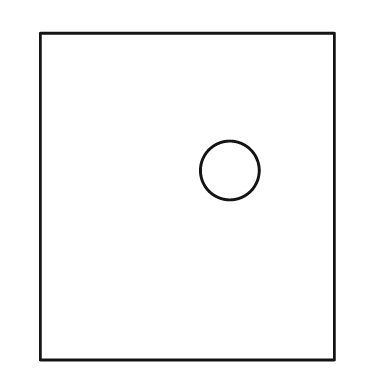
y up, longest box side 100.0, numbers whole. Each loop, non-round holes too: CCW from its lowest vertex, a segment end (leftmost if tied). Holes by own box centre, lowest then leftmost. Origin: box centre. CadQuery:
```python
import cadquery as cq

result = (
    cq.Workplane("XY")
    .moveTo(-45.0, -50.0)
    .lineTo(45.0, -50.0)
    .lineTo(45.0, 50.0)
    .lineTo(-45.0, 50.0)
    .close()
    .moveTo(13.0, 8.0)
    .circle(9.0)
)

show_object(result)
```